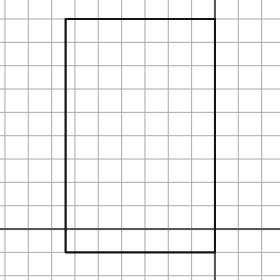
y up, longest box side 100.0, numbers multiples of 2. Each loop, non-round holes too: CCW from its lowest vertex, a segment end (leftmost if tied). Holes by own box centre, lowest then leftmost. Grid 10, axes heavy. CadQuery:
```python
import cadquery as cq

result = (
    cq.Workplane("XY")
    .moveTo(-64.0, -10.0)
    .lineTo(0.0, -10.0)
    .lineTo(0.0, 90.0)
    .lineTo(-64.0, 90.0)
    .close()
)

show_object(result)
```